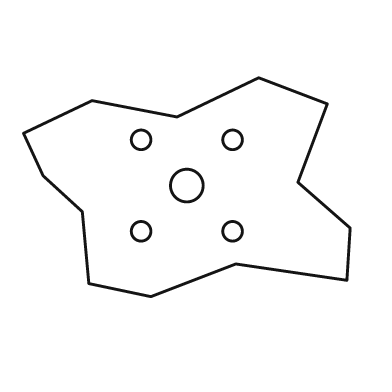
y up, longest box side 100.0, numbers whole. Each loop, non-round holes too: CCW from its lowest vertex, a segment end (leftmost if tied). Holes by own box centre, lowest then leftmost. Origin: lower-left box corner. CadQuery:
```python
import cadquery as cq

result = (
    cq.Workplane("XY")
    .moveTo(39.0, 0.0)
    .lineTo(65.0, 10.0)
    .lineTo(99.0, 5.0)
    .lineTo(100.0, 21.0)
    .lineTo(84.0, 35.0)
    .lineTo(93.0, 59.0)
    .lineTo(72.0, 67.0)
    .lineTo(47.0, 55.0)
    .lineTo(21.0, 60.0)
    .lineTo(0.0, 50.0)
    .lineTo(6.0, 37.0)
    .lineTo(18.0, 26.0)
    .lineTo(20.0, 4.0)
    .close()
    .moveTo(36.0, 20.0)
    .circle(3.0)
    .moveTo(64.0, 20.0)
    .circle(3.0)
    .moveTo(50.0, 34.0)
    .circle(5.0)
    .moveTo(36.0, 48.0)
    .circle(3.0)
    .moveTo(64.0, 48.0)
    .circle(3.0)
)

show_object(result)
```